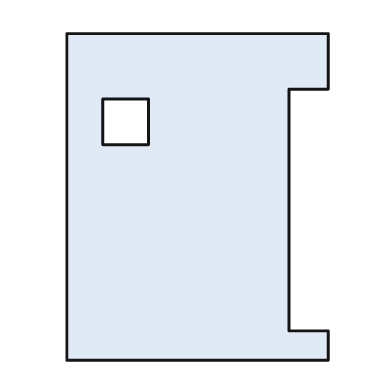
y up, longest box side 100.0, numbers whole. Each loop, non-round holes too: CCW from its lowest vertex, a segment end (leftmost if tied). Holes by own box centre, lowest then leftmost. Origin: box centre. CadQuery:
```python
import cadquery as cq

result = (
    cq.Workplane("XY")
    .moveTo(-40.0, -50.0)
    .lineTo(40.0, -50.0)
    .lineTo(40.0, -41.0)
    .lineTo(28.0, -41.0)
    .lineTo(28.0, 33.0)
    .lineTo(40.0, 33.0)
    .lineTo(40.0, 50.0)
    .lineTo(-40.0, 50.0)
    .close()
    .moveTo(-29.0, 16.0)
    .lineTo(-15.0, 16.0)
    .lineTo(-15.0, 30.0)
    .lineTo(-29.0, 30.0)
    .close()
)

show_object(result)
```